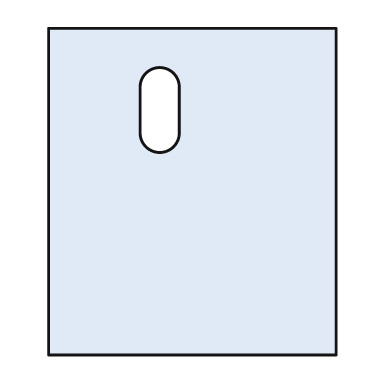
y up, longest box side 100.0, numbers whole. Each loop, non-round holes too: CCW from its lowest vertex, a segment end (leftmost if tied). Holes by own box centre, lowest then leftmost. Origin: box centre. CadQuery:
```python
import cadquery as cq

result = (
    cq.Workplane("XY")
    .moveTo(-44.0, -50.0)
    .lineTo(44.0, -50.0)
    .lineTo(44.0, 50.0)
    .lineTo(-44.0, 50.0)
    .close()
    .moveTo(-16.0, 18.0)
    .threePointArc((-10.0, 12.0), (-4.0, 18.0))
    .lineTo(-4.0, 32.0)
    .threePointArc((-10.0, 38.0), (-16.0, 32.0))
    .close()
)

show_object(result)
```